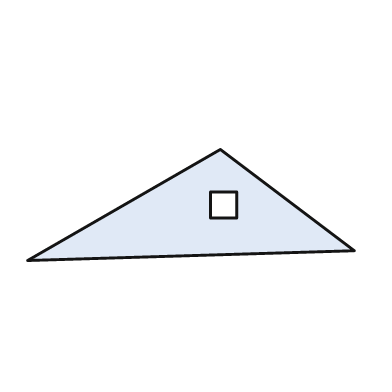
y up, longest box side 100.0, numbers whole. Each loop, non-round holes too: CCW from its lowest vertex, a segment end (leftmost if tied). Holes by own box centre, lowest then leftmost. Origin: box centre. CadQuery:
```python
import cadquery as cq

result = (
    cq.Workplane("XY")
    .moveTo(-50.0, -17.0)
    .lineTo(50.0, -14.0)
    .lineTo(9.0, 17.0)
    .close()
    .moveTo(6.0, -4.0)
    .lineTo(14.0, -4.0)
    .lineTo(14.0, 4.0)
    .lineTo(6.0, 4.0)
    .close()
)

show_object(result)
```